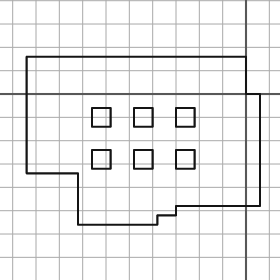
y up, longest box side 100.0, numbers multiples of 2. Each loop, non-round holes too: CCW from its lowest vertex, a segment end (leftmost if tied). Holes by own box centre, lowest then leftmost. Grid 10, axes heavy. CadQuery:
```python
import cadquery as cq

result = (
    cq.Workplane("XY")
    .moveTo(-72.0, -56.0)
    .lineTo(-38.0, -56.0)
    .lineTo(-38.0, -52.0)
    .lineTo(-30.0, -52.0)
    .lineTo(-30.0, -48.0)
    .lineTo(6.0, -48.0)
    .lineTo(6.0, 0.0)
    .lineTo(0.0, 0.0)
    .lineTo(0.0, 16.0)
    .lineTo(-94.0, 16.0)
    .lineTo(-94.0, -34.0)
    .lineTo(-72.0, -34.0)
    .close()
    .moveTo(-66.0, -32.0)
    .lineTo(-58.0, -32.0)
    .lineTo(-58.0, -24.0)
    .lineTo(-66.0, -24.0)
    .close()
    .moveTo(-48.0, -32.0)
    .lineTo(-40.0, -32.0)
    .lineTo(-40.0, -24.0)
    .lineTo(-48.0, -24.0)
    .close()
    .moveTo(-30.0, -32.0)
    .lineTo(-22.0, -32.0)
    .lineTo(-22.0, -24.0)
    .lineTo(-30.0, -24.0)
    .close()
    .moveTo(-66.0, -14.0)
    .lineTo(-58.0, -14.0)
    .lineTo(-58.0, -6.0)
    .lineTo(-66.0, -6.0)
    .close()
    .moveTo(-48.0, -14.0)
    .lineTo(-40.0, -14.0)
    .lineTo(-40.0, -6.0)
    .lineTo(-48.0, -6.0)
    .close()
    .moveTo(-30.0, -14.0)
    .lineTo(-22.0, -14.0)
    .lineTo(-22.0, -6.0)
    .lineTo(-30.0, -6.0)
    .close()
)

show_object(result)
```